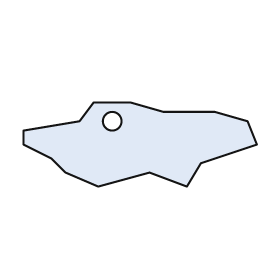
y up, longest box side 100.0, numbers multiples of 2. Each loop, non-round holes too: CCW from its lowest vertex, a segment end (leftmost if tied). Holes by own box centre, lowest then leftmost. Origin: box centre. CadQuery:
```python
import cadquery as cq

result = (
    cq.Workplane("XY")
    .moveTo(-18.0, -18.0)
    .lineTo(4.0, -12.0)
    .lineTo(20.0, -18.0)
    .lineTo(26.0, -8.0)
    .lineTo(50.0, 0.0)
    .lineTo(46.0, 10.0)
    .lineTo(32.0, 14.0)
    .lineTo(10.0, 14.0)
    .lineTo(-4.0, 18.0)
    .lineTo(-20.0, 18.0)
    .lineTo(-26.0, 10.0)
    .lineTo(-50.0, 6.0)
    .lineTo(-50.0, 0.0)
    .lineTo(-38.0, -6.0)
    .lineTo(-32.0, -12.0)
    .close()
    .moveTo(-12.0, 10.0)
    .circle(4.0)
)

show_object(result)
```